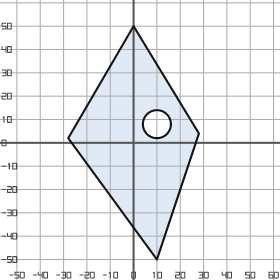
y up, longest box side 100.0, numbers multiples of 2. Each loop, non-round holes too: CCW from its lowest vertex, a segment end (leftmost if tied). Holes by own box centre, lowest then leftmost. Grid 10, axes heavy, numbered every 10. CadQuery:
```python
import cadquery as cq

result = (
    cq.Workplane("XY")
    .moveTo(10.0, -50.0)
    .lineTo(28.0, 4.0)
    .lineTo(0.0, 50.0)
    .lineTo(-28.0, 2.0)
    .close()
    .moveTo(10.0, 8.0)
    .circle(6.0)
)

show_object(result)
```